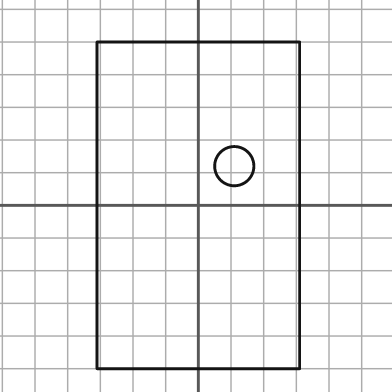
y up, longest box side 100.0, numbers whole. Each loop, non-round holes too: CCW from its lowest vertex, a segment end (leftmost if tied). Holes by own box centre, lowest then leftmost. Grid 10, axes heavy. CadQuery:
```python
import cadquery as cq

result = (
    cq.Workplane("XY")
    .moveTo(-31.0, -50.0)
    .lineTo(31.0, -50.0)
    .lineTo(31.0, 50.0)
    .lineTo(-31.0, 50.0)
    .close()
    .moveTo(11.0, 12.0)
    .circle(6.0)
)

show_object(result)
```